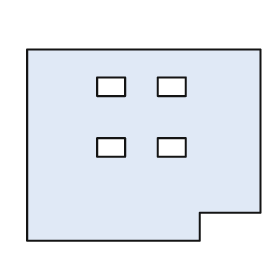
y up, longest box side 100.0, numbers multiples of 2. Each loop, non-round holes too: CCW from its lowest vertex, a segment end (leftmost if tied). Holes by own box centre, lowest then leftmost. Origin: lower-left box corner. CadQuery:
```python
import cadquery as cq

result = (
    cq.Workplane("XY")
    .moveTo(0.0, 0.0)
    .lineTo(74.0, 0.0)
    .lineTo(74.0, 12.0)
    .lineTo(100.0, 12.0)
    .lineTo(100.0, 82.0)
    .lineTo(0.0, 82.0)
    .close()
    .moveTo(30.0, 36.0)
    .lineTo(42.0, 36.0)
    .lineTo(42.0, 44.0)
    .lineTo(30.0, 44.0)
    .close()
    .moveTo(56.0, 36.0)
    .lineTo(68.0, 36.0)
    .lineTo(68.0, 44.0)
    .lineTo(56.0, 44.0)
    .close()
    .moveTo(30.0, 62.0)
    .lineTo(42.0, 62.0)
    .lineTo(42.0, 70.0)
    .lineTo(30.0, 70.0)
    .close()
    .moveTo(56.0, 62.0)
    .lineTo(68.0, 62.0)
    .lineTo(68.0, 70.0)
    .lineTo(56.0, 70.0)
    .close()
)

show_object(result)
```